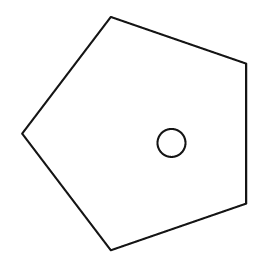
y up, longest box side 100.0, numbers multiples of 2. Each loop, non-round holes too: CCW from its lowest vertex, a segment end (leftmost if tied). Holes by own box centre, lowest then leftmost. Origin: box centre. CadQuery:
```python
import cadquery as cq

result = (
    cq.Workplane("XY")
    .moveTo(-10.0, -50.0)
    .lineTo(48.0, -30.0)
    .lineTo(48.0, 30.0)
    .lineTo(-10.0, 50.0)
    .lineTo(-48.0, 0.0)
    .close()
    .moveTo(16.0, -4.0)
    .circle(6.0)
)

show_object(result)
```